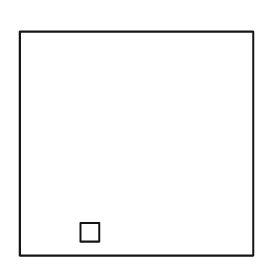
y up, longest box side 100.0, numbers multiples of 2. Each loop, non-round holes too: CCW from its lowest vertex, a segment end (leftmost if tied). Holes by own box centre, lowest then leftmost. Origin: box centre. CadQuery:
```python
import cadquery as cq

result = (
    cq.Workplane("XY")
    .moveTo(-50.0, -48.0)
    .lineTo(50.0, -48.0)
    .lineTo(50.0, 48.0)
    .lineTo(-50.0, 48.0)
    .close()
    .moveTo(-24.0, -42.0)
    .lineTo(-16.0, -42.0)
    .lineTo(-16.0, -34.0)
    .lineTo(-24.0, -34.0)
    .close()
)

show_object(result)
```